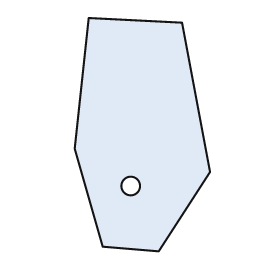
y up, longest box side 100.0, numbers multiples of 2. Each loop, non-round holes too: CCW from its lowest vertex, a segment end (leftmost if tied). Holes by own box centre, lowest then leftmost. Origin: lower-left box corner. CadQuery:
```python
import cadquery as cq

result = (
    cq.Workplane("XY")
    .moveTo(36.0, 0.0)
    .lineTo(58.0, 34.0)
    .lineTo(46.0, 98.0)
    .lineTo(6.0, 100.0)
    .lineTo(0.0, 44.0)
    .lineTo(12.0, 2.0)
    .close()
    .moveTo(24.0, 28.0)
    .circle(4.0)
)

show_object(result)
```